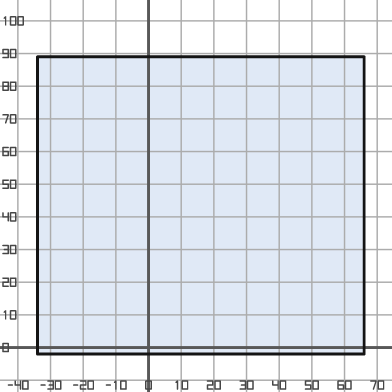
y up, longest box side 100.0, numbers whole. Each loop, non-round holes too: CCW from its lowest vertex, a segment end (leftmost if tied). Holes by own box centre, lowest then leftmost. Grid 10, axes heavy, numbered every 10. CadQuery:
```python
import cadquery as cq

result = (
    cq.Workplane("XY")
    .moveTo(-34.0, -2.0)
    .lineTo(66.0, -2.0)
    .lineTo(66.0, 89.0)
    .lineTo(-34.0, 89.0)
    .close()
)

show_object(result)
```